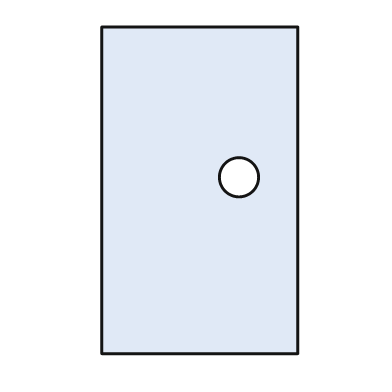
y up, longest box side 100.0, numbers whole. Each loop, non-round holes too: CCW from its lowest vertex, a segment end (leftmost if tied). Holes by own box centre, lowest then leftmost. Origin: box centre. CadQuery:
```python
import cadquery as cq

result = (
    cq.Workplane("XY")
    .moveTo(-30.0, -50.0)
    .lineTo(30.0, -50.0)
    .lineTo(30.0, 50.0)
    .lineTo(-30.0, 50.0)
    .close()
    .moveTo(12.0, 4.0)
    .circle(6.0)
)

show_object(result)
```